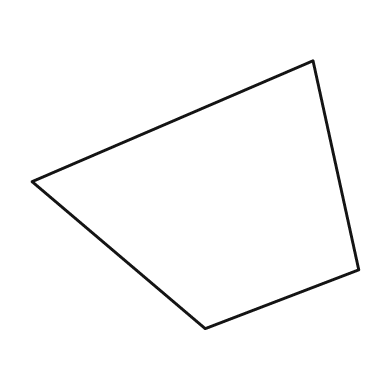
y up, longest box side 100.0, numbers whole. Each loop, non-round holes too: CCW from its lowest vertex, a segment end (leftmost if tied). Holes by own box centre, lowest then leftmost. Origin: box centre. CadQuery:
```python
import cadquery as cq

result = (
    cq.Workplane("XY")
    .moveTo(3.0, -41.0)
    .lineTo(50.0, -23.0)
    .lineTo(36.0, 41.0)
    .lineTo(-50.0, 4.0)
    .close()
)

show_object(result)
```